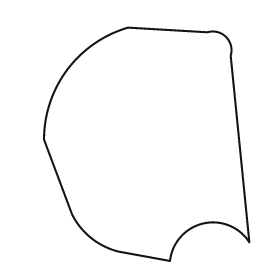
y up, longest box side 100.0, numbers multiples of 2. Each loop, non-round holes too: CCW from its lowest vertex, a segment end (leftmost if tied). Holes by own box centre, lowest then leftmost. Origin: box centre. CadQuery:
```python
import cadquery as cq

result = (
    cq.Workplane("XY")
    .moveTo(10.0, -50.0)
    .threePointArc((24.0, -34.0), (44.0, -42.0))
    .lineTo(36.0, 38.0)
    .threePointArc((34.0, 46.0), (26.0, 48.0))
    .lineTo(-8.0, 50.0)
    .threePointArc((-34.0, 32.0), (-44.0, 2.0))
    .lineTo(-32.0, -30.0)
    .threePointArc((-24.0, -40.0), (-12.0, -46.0))
    .close()
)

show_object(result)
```